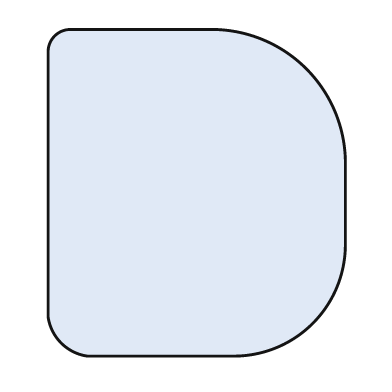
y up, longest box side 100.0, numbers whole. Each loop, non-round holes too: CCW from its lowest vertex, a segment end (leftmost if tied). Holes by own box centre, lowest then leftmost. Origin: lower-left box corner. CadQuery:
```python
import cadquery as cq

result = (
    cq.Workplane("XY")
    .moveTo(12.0, 0.0)
    .lineTo(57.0, 0.0)
    .threePointArc((81.0, 10.0), (91.0, 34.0))
    .lineTo(91.0, 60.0)
    .threePointArc((79.0, 88.0), (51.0, 100.0))
    .lineTo(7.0, 100.0)
    .threePointArc((2.0, 98.0), (0.0, 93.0))
    .lineTo(0.0, 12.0)
    .threePointArc((4.0, 4.0), (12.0, 0.0))
    .close()
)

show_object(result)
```